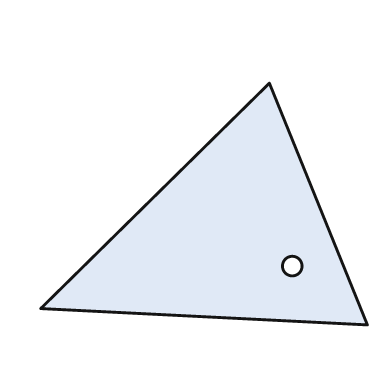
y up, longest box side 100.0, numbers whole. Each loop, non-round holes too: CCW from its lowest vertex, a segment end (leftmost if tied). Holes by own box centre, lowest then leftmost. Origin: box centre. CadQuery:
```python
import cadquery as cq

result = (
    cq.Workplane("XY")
    .moveTo(50.0, -37.0)
    .lineTo(20.0, 37.0)
    .lineTo(-50.0, -32.0)
    .close()
    .moveTo(27.0, -19.0)
    .circle(3.0)
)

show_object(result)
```